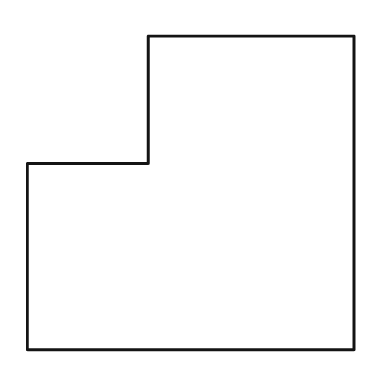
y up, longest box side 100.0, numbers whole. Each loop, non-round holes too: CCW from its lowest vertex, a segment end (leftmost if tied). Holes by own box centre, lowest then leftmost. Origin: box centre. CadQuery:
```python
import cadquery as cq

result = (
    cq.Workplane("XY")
    .moveTo(-50.0, -48.0)
    .lineTo(50.0, -48.0)
    .lineTo(50.0, 48.0)
    .lineTo(-13.0, 48.0)
    .lineTo(-13.0, 9.0)
    .lineTo(-50.0, 9.0)
    .close()
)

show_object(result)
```